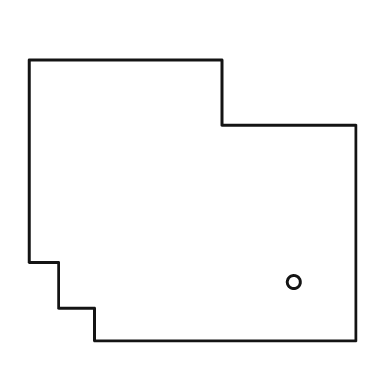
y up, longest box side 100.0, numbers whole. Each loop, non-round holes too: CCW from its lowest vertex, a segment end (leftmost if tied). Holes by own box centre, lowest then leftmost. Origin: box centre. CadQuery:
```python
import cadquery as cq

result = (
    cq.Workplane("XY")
    .moveTo(-30.0, -43.0)
    .lineTo(50.0, -43.0)
    .lineTo(50.0, 23.0)
    .lineTo(9.0, 23.0)
    .lineTo(9.0, 43.0)
    .lineTo(-50.0, 43.0)
    .lineTo(-50.0, -19.0)
    .lineTo(-41.0, -19.0)
    .lineTo(-41.0, -33.0)
    .lineTo(-30.0, -33.0)
    .close()
    .moveTo(31.0, -25.0)
    .circle(2.0)
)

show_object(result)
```